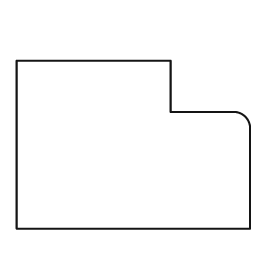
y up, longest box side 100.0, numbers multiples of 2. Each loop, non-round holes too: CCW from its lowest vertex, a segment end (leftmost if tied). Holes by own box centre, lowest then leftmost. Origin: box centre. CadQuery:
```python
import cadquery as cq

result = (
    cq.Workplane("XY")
    .moveTo(-50.0, -36.0)
    .lineTo(50.0, -36.0)
    .lineTo(50.0, 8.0)
    .threePointArc((48.0, 12.0), (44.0, 14.0))
    .lineTo(16.0, 14.0)
    .lineTo(16.0, 36.0)
    .lineTo(-50.0, 36.0)
    .close()
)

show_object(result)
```